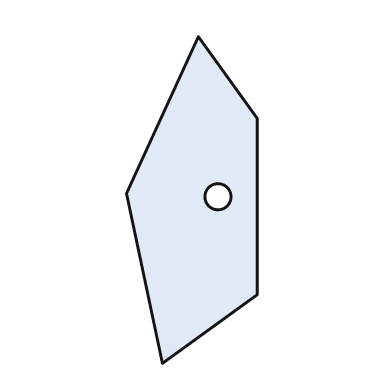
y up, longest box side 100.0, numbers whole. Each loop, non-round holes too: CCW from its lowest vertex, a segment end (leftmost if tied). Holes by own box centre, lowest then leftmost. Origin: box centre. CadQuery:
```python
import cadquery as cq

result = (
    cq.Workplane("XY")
    .moveTo(-9.0, -50.0)
    .lineTo(20.0, -29.0)
    .lineTo(20.0, 25.0)
    .lineTo(2.0, 50.0)
    .lineTo(-20.0, 2.0)
    .close()
    .moveTo(8.0, 1.0)
    .circle(4.0)
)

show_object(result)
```